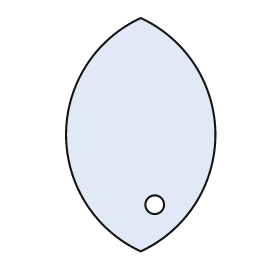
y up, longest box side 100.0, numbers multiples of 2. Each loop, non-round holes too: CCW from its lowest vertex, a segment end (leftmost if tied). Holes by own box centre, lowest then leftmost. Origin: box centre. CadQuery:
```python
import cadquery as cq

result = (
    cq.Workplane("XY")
    .moveTo(0.0, -50.0)
    .threePointArc((32.0, 0.0), (0.0, 50.0))
    .threePointArc((-32.0, 0.0), (0.0, -50.0))
    .close()
    .moveTo(6.0, -30.0)
    .circle(4.0)
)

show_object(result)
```